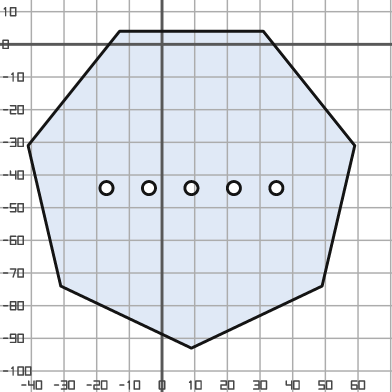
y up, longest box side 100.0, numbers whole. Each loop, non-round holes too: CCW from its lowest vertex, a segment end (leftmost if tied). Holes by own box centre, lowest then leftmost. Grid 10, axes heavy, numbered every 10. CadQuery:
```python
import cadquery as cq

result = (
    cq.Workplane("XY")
    .moveTo(9.0, -93.0)
    .lineTo(49.0, -74.0)
    .lineTo(59.0, -31.0)
    .lineTo(31.0, 4.0)
    .lineTo(-13.0, 4.0)
    .lineTo(-41.0, -31.0)
    .lineTo(-31.0, -74.0)
    .close()
    .moveTo(-17.0, -44.0)
    .circle(2.0)
    .moveTo(-4.0, -44.0)
    .circle(2.0)
    .moveTo(9.0, -44.0)
    .circle(2.0)
    .moveTo(22.0, -44.0)
    .circle(2.0)
    .moveTo(35.0, -44.0)
    .circle(2.0)
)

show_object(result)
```